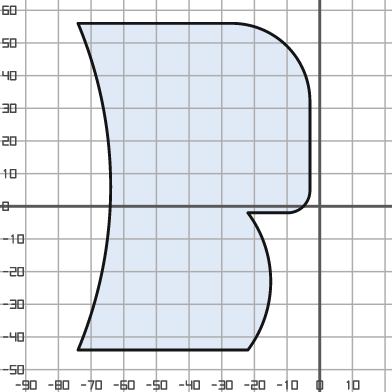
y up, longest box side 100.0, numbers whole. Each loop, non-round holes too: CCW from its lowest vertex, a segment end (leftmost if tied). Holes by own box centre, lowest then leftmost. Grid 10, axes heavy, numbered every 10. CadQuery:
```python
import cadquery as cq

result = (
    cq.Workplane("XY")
    .moveTo(-74.0, -44.0)
    .lineTo(-22.0, -44.0)
    .threePointArc((-15.0, -23.0), (-22.0, -2.0))
    .lineTo(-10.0, -2.0)
    .threePointArc((-5.0, 0.0), (-3.0, 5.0))
    .lineTo(-3.0, 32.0)
    .threePointArc((-10.0, 49.0), (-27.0, 56.0))
    .lineTo(-74.0, 56.0)
    .threePointArc((-64.0, 6.0), (-74.0, -44.0))
    .close()
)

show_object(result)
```